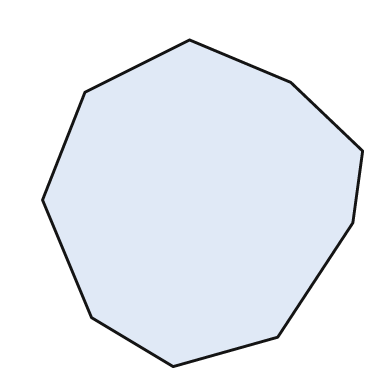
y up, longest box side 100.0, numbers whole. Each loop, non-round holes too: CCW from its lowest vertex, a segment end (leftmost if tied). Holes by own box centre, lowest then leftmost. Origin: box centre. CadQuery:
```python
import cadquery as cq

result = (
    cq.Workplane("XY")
    .moveTo(-9.0, -50.0)
    .lineTo(23.0, -41.0)
    .lineTo(46.0, -6.0)
    .lineTo(49.0, 16.0)
    .lineTo(27.0, 37.0)
    .lineTo(-4.0, 50.0)
    .lineTo(-36.0, 34.0)
    .lineTo(-49.0, 1.0)
    .lineTo(-34.0, -35.0)
    .close()
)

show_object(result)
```